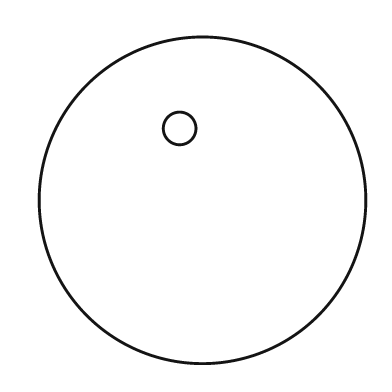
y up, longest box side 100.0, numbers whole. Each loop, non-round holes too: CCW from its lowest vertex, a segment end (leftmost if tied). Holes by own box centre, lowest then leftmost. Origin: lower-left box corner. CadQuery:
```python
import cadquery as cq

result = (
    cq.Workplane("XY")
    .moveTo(50.0, 50.0)
    .circle(50.0)
    .moveTo(43.0, 72.0)
    .circle(5.0)
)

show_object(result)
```